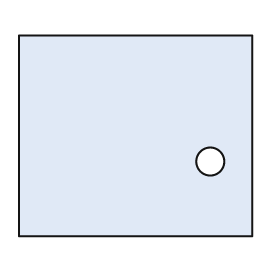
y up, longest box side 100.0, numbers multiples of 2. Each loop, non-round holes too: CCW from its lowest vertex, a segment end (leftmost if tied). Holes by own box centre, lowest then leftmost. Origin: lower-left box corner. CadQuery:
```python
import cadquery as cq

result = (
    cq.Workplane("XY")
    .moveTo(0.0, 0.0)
    .lineTo(100.0, 0.0)
    .lineTo(100.0, 86.0)
    .lineTo(0.0, 86.0)
    .close()
    .moveTo(82.0, 32.0)
    .circle(6.0)
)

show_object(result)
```